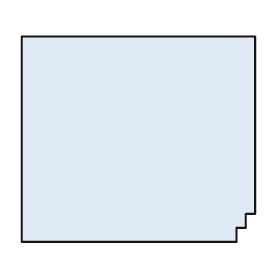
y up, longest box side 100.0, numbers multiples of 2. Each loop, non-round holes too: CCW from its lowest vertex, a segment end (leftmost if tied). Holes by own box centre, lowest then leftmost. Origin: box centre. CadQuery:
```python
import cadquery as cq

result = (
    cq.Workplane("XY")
    .moveTo(-50.0, -44.0)
    .lineTo(42.0, -44.0)
    .lineTo(42.0, -38.0)
    .lineTo(46.0, -38.0)
    .lineTo(46.0, -32.0)
    .lineTo(50.0, -32.0)
    .lineTo(50.0, 44.0)
    .lineTo(-50.0, 44.0)
    .close()
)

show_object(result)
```